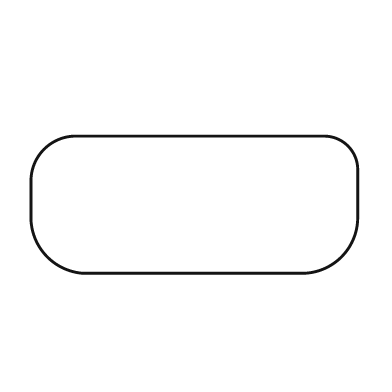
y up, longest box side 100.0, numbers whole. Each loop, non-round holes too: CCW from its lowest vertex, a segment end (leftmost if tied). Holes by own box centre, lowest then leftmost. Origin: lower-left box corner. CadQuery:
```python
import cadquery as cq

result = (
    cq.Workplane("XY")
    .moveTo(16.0, 0.0)
    .lineTo(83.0, 0.0)
    .threePointArc((95.0, 5.0), (100.0, 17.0))
    .lineTo(100.0, 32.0)
    .threePointArc((97.0, 39.0), (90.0, 42.0))
    .lineTo(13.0, 42.0)
    .threePointArc((4.0, 38.0), (0.0, 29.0))
    .lineTo(0.0, 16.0)
    .threePointArc((5.0, 5.0), (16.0, 0.0))
    .close()
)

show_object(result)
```